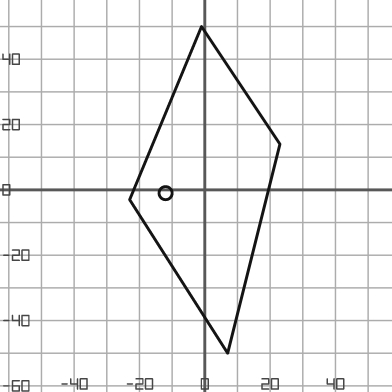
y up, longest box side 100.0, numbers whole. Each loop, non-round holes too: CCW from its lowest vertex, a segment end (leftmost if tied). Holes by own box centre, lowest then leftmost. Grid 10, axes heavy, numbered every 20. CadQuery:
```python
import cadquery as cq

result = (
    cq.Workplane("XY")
    .moveTo(7.0, -50.0)
    .lineTo(23.0, 14.0)
    .lineTo(-1.0, 50.0)
    .lineTo(-23.0, -3.0)
    .close()
    .moveTo(-12.0, -1.0)
    .circle(2.0)
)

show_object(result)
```